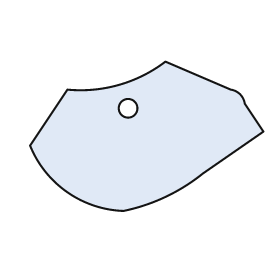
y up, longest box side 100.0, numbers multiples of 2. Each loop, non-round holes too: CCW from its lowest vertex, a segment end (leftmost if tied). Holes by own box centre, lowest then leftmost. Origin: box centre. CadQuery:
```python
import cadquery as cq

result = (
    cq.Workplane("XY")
    .moveTo(-10.0, -32.0)
    .threePointArc((8.0, -26.0), (24.0, -16.0))
    .lineTo(50.0, 2.0)
    .lineTo(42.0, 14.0)
    .threePointArc((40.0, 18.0), (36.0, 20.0))
    .lineTo(8.0, 32.0)
    .threePointArc((-12.0, 22.0), (-34.0, 20.0))
    .lineTo(-50.0, -4.0)
    .threePointArc((-34.0, -24.0), (-10.0, -32.0))
    .close()
    .moveTo(-8.0, 12.0)
    .circle(4.0)
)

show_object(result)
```